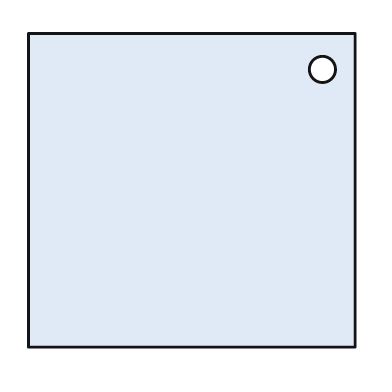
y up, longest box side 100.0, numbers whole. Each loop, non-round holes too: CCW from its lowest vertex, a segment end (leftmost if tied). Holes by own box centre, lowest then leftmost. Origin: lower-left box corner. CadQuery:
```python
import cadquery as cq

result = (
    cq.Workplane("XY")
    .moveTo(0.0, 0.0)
    .lineTo(100.0, 0.0)
    .lineTo(100.0, 96.0)
    .lineTo(0.0, 96.0)
    .close()
    .moveTo(90.0, 85.0)
    .circle(4.0)
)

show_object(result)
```